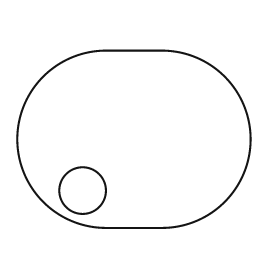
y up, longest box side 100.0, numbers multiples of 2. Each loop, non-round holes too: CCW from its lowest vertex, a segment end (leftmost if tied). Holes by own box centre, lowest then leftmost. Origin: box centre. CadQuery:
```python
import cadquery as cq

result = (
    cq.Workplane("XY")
    .moveTo(-12.0, -38.0)
    .lineTo(12.0, -38.0)
    .threePointArc((50.0, 0.0), (12.0, 38.0))
    .lineTo(-12.0, 38.0)
    .threePointArc((-50.0, 0.0), (-12.0, -38.0))
    .close()
    .moveTo(-22.0, -22.0)
    .circle(10.0)
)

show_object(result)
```